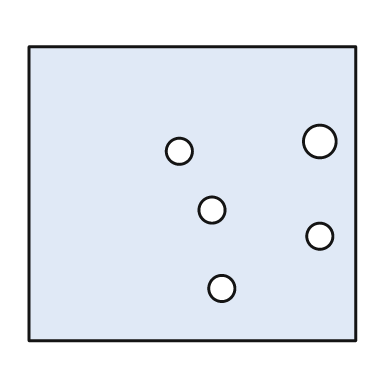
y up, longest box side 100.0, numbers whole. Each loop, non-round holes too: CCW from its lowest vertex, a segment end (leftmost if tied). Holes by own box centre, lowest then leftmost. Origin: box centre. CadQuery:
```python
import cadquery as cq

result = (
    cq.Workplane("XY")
    .moveTo(-50.0, -45.0)
    .lineTo(50.0, -45.0)
    .lineTo(50.0, 45.0)
    .lineTo(-50.0, 45.0)
    .close()
    .moveTo(9.0, -29.0)
    .circle(4.0)
    .moveTo(39.0, -13.0)
    .circle(4.0)
    .moveTo(6.0, -5.0)
    .circle(4.0)
    .moveTo(-4.0, 13.0)
    .circle(4.0)
    .moveTo(39.0, 16.0)
    .circle(5.0)
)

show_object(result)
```